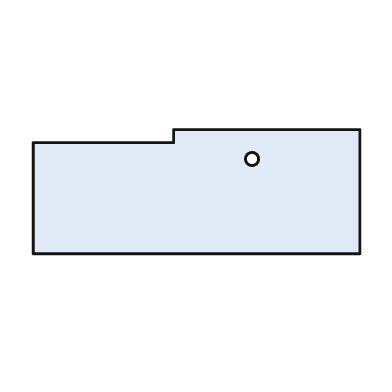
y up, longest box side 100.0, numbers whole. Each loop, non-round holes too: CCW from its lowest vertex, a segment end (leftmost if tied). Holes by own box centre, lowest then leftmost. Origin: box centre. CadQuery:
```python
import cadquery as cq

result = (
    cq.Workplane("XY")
    .moveTo(-50.0, -19.0)
    .lineTo(50.0, -19.0)
    .lineTo(50.0, 19.0)
    .lineTo(-7.0, 19.0)
    .lineTo(-7.0, 15.0)
    .lineTo(-50.0, 15.0)
    .close()
    .moveTo(17.0, 10.0)
    .circle(2.0)
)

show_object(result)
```